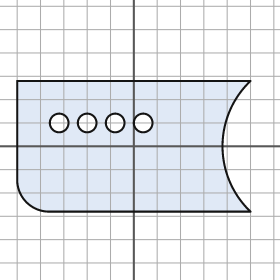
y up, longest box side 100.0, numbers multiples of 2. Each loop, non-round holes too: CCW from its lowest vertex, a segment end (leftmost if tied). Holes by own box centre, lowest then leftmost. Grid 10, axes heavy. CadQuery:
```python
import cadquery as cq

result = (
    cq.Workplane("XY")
    .moveTo(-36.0, -28.0)
    .lineTo(50.0, -28.0)
    .threePointArc((38.0, 0.0), (50.0, 28.0))
    .lineTo(-50.0, 28.0)
    .lineTo(-50.0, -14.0)
    .threePointArc((-46.0, -24.0), (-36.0, -28.0))
    .close()
    .moveTo(-32.0, 10.0)
    .circle(4.0)
    .moveTo(-20.0, 10.0)
    .circle(4.0)
    .moveTo(-8.0, 10.0)
    .circle(4.0)
    .moveTo(4.0, 10.0)
    .circle(4.0)
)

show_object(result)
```